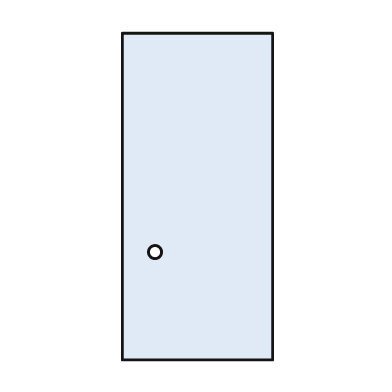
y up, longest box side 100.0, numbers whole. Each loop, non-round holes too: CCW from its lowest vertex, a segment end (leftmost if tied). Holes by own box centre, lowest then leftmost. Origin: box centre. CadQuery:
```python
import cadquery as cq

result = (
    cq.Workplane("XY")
    .moveTo(-23.0, -50.0)
    .lineTo(23.0, -50.0)
    .lineTo(23.0, 50.0)
    .lineTo(-23.0, 50.0)
    .close()
    .moveTo(-13.0, -17.0)
    .circle(2.0)
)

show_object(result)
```